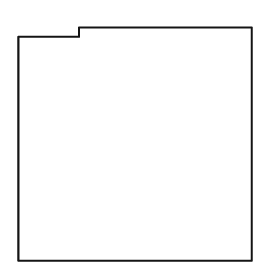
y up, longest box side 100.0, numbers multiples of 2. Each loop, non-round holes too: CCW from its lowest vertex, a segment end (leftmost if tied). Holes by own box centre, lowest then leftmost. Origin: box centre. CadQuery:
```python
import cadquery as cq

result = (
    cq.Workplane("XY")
    .moveTo(-50.0, -50.0)
    .lineTo(50.0, -50.0)
    .lineTo(50.0, 50.0)
    .lineTo(-24.0, 50.0)
    .lineTo(-24.0, 46.0)
    .lineTo(-50.0, 46.0)
    .close()
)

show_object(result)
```